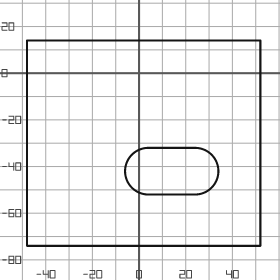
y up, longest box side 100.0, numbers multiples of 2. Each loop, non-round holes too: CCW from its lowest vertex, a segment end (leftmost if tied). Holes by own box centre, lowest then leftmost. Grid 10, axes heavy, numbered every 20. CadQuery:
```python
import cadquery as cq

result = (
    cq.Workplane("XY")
    .moveTo(-48.0, -74.0)
    .lineTo(52.0, -74.0)
    .lineTo(52.0, 14.0)
    .lineTo(-48.0, 14.0)
    .close()
    .moveTo(4.0, -52.0)
    .lineTo(24.0, -52.0)
    .threePointArc((34.0, -42.0), (24.0, -32.0))
    .lineTo(4.0, -32.0)
    .threePointArc((-6.0, -42.0), (4.0, -52.0))
    .close()
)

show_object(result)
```